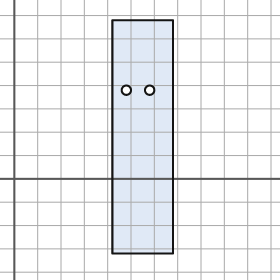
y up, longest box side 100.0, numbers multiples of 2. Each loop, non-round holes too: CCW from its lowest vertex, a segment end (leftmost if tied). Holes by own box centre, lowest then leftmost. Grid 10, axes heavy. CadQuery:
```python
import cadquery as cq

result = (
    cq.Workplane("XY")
    .moveTo(42.0, -32.0)
    .lineTo(68.0, -32.0)
    .lineTo(68.0, 68.0)
    .lineTo(42.0, 68.0)
    .close()
    .moveTo(48.0, 38.0)
    .circle(2.0)
    .moveTo(58.0, 38.0)
    .circle(2.0)
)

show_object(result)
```